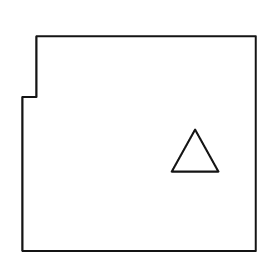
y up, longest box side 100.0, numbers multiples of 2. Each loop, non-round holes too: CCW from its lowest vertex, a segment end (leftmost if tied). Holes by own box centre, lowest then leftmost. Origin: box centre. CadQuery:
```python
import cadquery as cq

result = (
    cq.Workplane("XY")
    .moveTo(-50.0, -46.0)
    .lineTo(50.0, -46.0)
    .lineTo(50.0, 46.0)
    .lineTo(-44.0, 46.0)
    .lineTo(-44.0, 20.0)
    .lineTo(-50.0, 20.0)
    .close()
    .moveTo(14.0, -12.0)
    .lineTo(34.0, -12.0)
    .lineTo(24.0, 6.0)
    .close()
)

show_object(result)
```